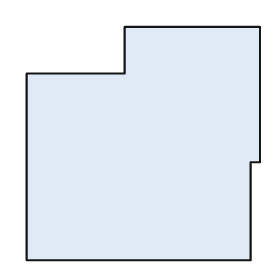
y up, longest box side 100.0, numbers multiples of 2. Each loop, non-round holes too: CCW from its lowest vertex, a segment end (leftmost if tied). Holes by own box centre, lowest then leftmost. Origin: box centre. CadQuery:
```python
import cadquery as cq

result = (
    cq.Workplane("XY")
    .moveTo(-50.0, -50.0)
    .lineTo(46.0, -50.0)
    .lineTo(46.0, -8.0)
    .lineTo(50.0, -8.0)
    .lineTo(50.0, 50.0)
    .lineTo(-8.0, 50.0)
    .lineTo(-8.0, 30.0)
    .lineTo(-50.0, 30.0)
    .close()
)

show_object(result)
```